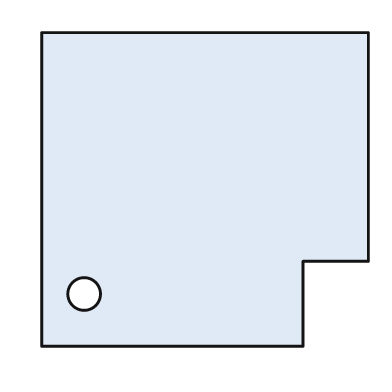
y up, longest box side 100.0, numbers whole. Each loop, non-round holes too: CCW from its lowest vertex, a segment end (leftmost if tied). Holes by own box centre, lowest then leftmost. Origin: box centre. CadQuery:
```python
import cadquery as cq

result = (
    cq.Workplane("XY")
    .moveTo(-50.0, -48.0)
    .lineTo(30.0, -48.0)
    .lineTo(30.0, -22.0)
    .lineTo(50.0, -22.0)
    .lineTo(50.0, 48.0)
    .lineTo(-50.0, 48.0)
    .close()
    .moveTo(-37.0, -32.0)
    .circle(5.0)
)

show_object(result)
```